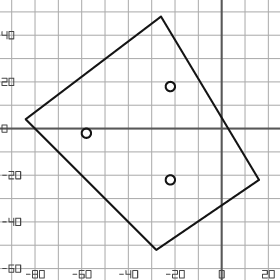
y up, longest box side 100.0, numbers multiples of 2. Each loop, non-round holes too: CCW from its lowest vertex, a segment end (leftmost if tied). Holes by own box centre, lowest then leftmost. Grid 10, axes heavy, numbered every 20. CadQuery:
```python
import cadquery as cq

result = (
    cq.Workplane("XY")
    .moveTo(-28.0, -52.0)
    .lineTo(16.0, -22.0)
    .lineTo(-26.0, 48.0)
    .lineTo(-84.0, 4.0)
    .close()
    .moveTo(-22.0, -22.0)
    .circle(2.0)
    .moveTo(-58.0, -2.0)
    .circle(2.0)
    .moveTo(-22.0, 18.0)
    .circle(2.0)
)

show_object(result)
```